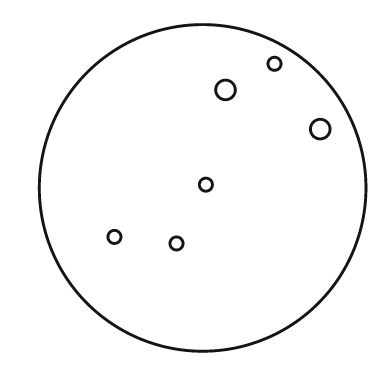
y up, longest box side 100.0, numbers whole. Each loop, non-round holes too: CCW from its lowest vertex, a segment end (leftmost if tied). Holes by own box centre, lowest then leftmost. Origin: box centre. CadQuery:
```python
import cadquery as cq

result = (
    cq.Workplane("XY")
    .moveTo(0.0, 0.0)
    .circle(50.0)
    .moveTo(-8.0, -17.0)
    .circle(2.0)
    .moveTo(-27.0, -15.0)
    .circle(2.0)
    .moveTo(1.0, 1.0)
    .circle(2.0)
    .moveTo(36.0, 18.0)
    .circle(3.0)
    .moveTo(7.0, 30.0)
    .circle(3.0)
    .moveTo(22.0, 38.0)
    .circle(2.0)
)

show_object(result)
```